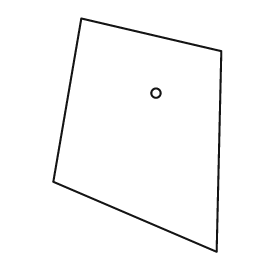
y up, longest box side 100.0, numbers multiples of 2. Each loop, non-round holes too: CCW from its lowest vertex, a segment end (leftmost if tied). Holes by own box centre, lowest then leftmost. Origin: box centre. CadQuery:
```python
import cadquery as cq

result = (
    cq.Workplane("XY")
    .moveTo(34.0, -50.0)
    .lineTo(36.0, 36.0)
    .lineTo(-24.0, 50.0)
    .lineTo(-36.0, -20.0)
    .close()
    .moveTo(8.0, 18.0)
    .circle(2.0)
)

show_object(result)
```